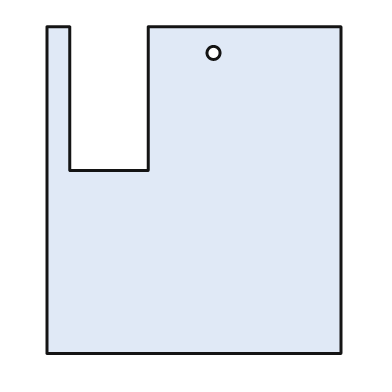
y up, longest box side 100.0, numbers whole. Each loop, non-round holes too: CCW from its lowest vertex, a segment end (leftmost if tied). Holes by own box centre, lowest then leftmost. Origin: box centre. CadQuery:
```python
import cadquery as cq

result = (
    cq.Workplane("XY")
    .moveTo(-45.0, -50.0)
    .lineTo(45.0, -50.0)
    .lineTo(45.0, 50.0)
    .lineTo(-14.0, 50.0)
    .lineTo(-14.0, 6.0)
    .lineTo(-38.0, 6.0)
    .lineTo(-38.0, 50.0)
    .lineTo(-45.0, 50.0)
    .close()
    .moveTo(6.0, 42.0)
    .circle(2.0)
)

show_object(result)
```